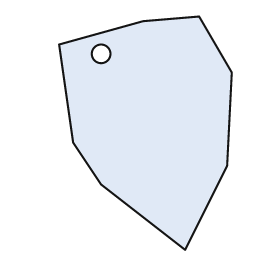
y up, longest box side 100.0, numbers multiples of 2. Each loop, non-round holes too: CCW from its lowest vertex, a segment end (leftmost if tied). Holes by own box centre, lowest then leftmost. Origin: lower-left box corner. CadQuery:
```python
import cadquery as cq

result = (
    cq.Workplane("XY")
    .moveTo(54.0, 0.0)
    .lineTo(72.0, 36.0)
    .lineTo(74.0, 76.0)
    .lineTo(60.0, 100.0)
    .lineTo(36.0, 98.0)
    .lineTo(0.0, 88.0)
    .lineTo(6.0, 46.0)
    .lineTo(18.0, 28.0)
    .close()
    .moveTo(18.0, 84.0)
    .circle(4.0)
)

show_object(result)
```